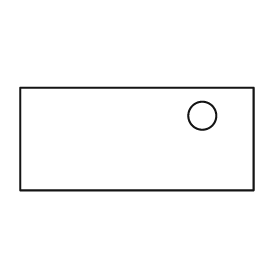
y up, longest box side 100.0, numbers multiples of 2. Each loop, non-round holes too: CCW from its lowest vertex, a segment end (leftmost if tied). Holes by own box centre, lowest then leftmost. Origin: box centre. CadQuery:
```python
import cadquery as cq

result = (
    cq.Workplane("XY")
    .moveTo(-50.0, -22.0)
    .lineTo(50.0, -22.0)
    .lineTo(50.0, 22.0)
    .lineTo(-50.0, 22.0)
    .close()
    .moveTo(28.0, 10.0)
    .circle(6.0)
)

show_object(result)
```